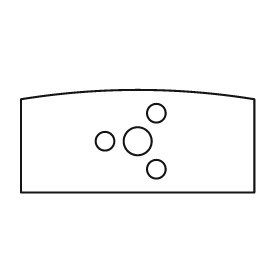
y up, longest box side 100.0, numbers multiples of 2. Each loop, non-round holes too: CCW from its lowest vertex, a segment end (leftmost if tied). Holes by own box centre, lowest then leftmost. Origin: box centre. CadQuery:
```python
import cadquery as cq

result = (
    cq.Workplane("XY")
    .moveTo(-50.0, -22.0)
    .lineTo(50.0, -22.0)
    .lineTo(50.0, 18.0)
    .threePointArc((0.0, 22.0), (-50.0, 18.0))
    .close()
    .moveTo(8.0, -12.0)
    .circle(4.0)
    .moveTo(-14.0, 0.0)
    .circle(4.0)
    .moveTo(0.0, 0.0)
    .circle(6.0)
    .moveTo(8.0, 12.0)
    .circle(4.0)
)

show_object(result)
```